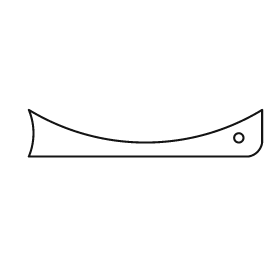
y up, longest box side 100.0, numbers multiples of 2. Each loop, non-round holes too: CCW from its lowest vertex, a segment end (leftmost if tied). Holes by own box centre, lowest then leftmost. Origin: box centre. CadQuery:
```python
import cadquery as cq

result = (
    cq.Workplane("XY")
    .moveTo(-50.0, -10.0)
    .lineTo(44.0, -10.0)
    .threePointArc((48.0, -8.0), (50.0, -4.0))
    .lineTo(50.0, 10.0)
    .threePointArc((0.0, -4.0), (-50.0, 10.0))
    .threePointArc((-48.0, 0.0), (-50.0, -10.0))
    .close()
    .moveTo(40.0, -2.0)
    .circle(2.0)
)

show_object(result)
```